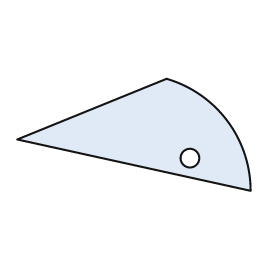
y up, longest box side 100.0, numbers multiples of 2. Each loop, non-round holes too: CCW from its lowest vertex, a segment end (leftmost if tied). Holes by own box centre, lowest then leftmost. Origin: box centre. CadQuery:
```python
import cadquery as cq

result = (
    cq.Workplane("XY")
    .moveTo(50.0, -24.0)
    .threePointArc((40.0, 6.0), (14.0, 24.0))
    .lineTo(-50.0, -2.0)
    .close()
    .moveTo(24.0, -10.0)
    .circle(4.0)
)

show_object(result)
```